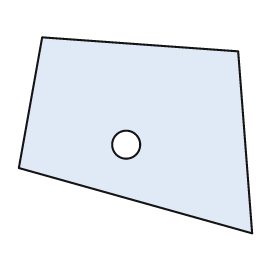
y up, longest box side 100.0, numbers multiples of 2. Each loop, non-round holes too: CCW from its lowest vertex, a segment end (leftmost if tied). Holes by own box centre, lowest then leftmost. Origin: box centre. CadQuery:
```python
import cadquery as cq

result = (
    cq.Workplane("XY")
    .moveTo(50.0, -42.0)
    .lineTo(44.0, 36.0)
    .lineTo(-40.0, 42.0)
    .lineTo(-50.0, -14.0)
    .close()
    .moveTo(-4.0, -4.0)
    .circle(6.0)
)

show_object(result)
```